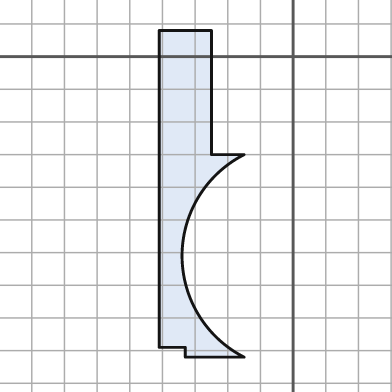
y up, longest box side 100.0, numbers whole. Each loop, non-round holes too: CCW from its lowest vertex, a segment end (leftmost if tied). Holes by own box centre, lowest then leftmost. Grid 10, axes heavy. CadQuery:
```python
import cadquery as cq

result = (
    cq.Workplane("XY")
    .moveTo(-33.0, -92.0)
    .lineTo(-15.0, -92.0)
    .threePointArc((-34.0, -61.0), (-15.0, -30.0))
    .lineTo(-25.0, -30.0)
    .lineTo(-25.0, 8.0)
    .lineTo(-41.0, 8.0)
    .lineTo(-41.0, -89.0)
    .lineTo(-33.0, -89.0)
    .close()
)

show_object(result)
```